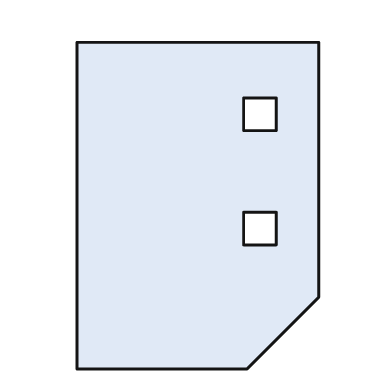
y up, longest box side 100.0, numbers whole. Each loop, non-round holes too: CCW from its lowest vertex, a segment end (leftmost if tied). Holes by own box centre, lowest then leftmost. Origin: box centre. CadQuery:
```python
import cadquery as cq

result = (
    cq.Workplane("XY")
    .moveTo(-37.0, -50.0)
    .lineTo(15.0, -50.0)
    .lineTo(37.0, -28.0)
    .lineTo(37.0, 50.0)
    .lineTo(-37.0, 50.0)
    .close()
    .moveTo(14.0, -12.0)
    .lineTo(24.0, -12.0)
    .lineTo(24.0, -2.0)
    .lineTo(14.0, -2.0)
    .close()
    .moveTo(14.0, 23.0)
    .lineTo(24.0, 23.0)
    .lineTo(24.0, 33.0)
    .lineTo(14.0, 33.0)
    .close()
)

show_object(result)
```